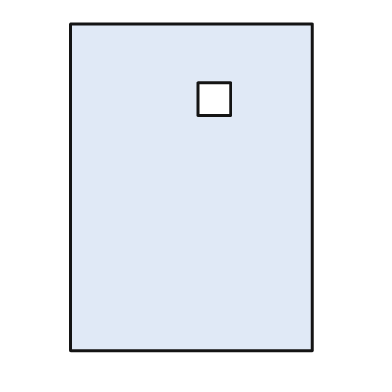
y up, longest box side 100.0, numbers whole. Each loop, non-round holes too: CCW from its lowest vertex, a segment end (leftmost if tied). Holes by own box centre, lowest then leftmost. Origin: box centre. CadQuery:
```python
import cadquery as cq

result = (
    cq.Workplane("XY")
    .moveTo(-37.0, -50.0)
    .lineTo(37.0, -50.0)
    .lineTo(37.0, 50.0)
    .lineTo(-37.0, 50.0)
    .close()
    .moveTo(2.0, 22.0)
    .lineTo(12.0, 22.0)
    .lineTo(12.0, 32.0)
    .lineTo(2.0, 32.0)
    .close()
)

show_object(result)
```